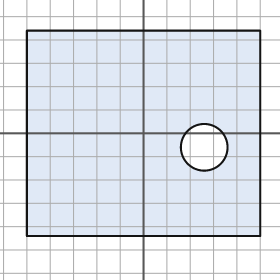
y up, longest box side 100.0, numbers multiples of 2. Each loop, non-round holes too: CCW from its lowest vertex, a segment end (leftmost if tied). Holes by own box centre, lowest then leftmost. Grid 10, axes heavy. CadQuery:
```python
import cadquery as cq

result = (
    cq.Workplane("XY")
    .moveTo(-50.0, -44.0)
    .lineTo(50.0, -44.0)
    .lineTo(50.0, 44.0)
    .lineTo(-50.0, 44.0)
    .close()
    .moveTo(26.0, -6.0)
    .circle(10.0)
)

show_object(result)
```